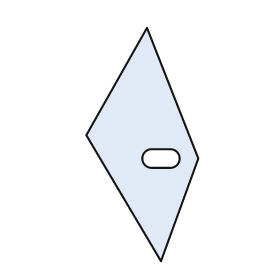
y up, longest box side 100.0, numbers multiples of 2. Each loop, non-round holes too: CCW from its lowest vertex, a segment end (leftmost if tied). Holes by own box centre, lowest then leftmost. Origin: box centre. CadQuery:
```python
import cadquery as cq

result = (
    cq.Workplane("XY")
    .moveTo(8.0, -50.0)
    .lineTo(24.0, -6.0)
    .lineTo(2.0, 50.0)
    .lineTo(-24.0, 4.0)
    .close()
    .moveTo(4.0, -10.0)
    .lineTo(12.0, -10.0)
    .threePointArc((16.0, -6.0), (12.0, -2.0))
    .lineTo(4.0, -2.0)
    .threePointArc((0.0, -6.0), (4.0, -10.0))
    .close()
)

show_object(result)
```